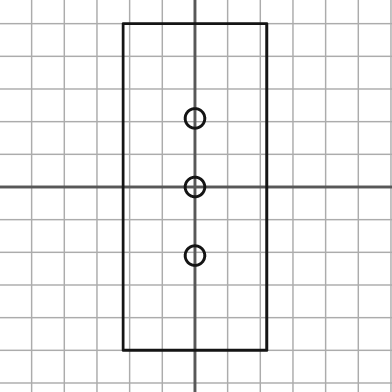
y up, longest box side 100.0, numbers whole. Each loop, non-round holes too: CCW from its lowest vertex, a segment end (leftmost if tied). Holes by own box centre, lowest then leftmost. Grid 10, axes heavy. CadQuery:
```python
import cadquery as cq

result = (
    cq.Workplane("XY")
    .moveTo(-22.0, -50.0)
    .lineTo(22.0, -50.0)
    .lineTo(22.0, 50.0)
    .lineTo(-22.0, 50.0)
    .close()
    .moveTo(0.0, -21.0)
    .circle(3.0)
    .moveTo(0.0, 0.0)
    .circle(3.0)
    .moveTo(0.0, 21.0)
    .circle(3.0)
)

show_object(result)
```